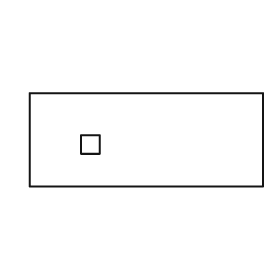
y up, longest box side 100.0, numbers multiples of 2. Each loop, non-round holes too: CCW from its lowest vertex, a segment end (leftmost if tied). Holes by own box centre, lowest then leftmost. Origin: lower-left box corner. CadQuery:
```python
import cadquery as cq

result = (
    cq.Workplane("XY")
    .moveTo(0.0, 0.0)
    .lineTo(100.0, 0.0)
    .lineTo(100.0, 40.0)
    .lineTo(0.0, 40.0)
    .close()
    .moveTo(22.0, 14.0)
    .lineTo(30.0, 14.0)
    .lineTo(30.0, 22.0)
    .lineTo(22.0, 22.0)
    .close()
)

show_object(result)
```